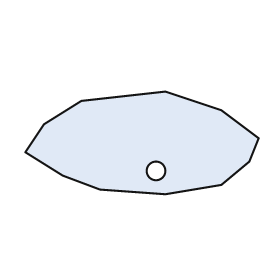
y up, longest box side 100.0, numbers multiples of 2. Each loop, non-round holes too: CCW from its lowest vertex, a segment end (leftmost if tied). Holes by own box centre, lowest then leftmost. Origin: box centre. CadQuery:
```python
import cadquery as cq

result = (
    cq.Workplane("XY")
    .moveTo(10.0, -22.0)
    .lineTo(34.0, -18.0)
    .lineTo(46.0, -8.0)
    .lineTo(50.0, 2.0)
    .lineTo(34.0, 14.0)
    .lineTo(10.0, 22.0)
    .lineTo(-26.0, 18.0)
    .lineTo(-42.0, 8.0)
    .lineTo(-50.0, -4.0)
    .lineTo(-34.0, -14.0)
    .lineTo(-18.0, -20.0)
    .close()
    .moveTo(6.0, -12.0)
    .circle(4.0)
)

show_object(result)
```